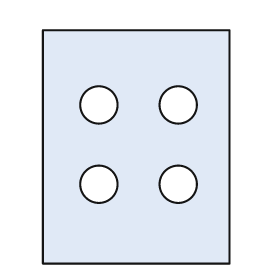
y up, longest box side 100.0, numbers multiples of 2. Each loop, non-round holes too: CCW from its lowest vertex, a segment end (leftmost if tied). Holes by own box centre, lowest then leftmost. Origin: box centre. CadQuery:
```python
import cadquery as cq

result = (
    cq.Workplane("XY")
    .moveTo(-40.0, -50.0)
    .lineTo(40.0, -50.0)
    .lineTo(40.0, 50.0)
    .lineTo(-40.0, 50.0)
    .close()
    .moveTo(-16.0, -16.0)
    .circle(8.0)
    .moveTo(18.0, -16.0)
    .circle(8.0)
    .moveTo(-16.0, 18.0)
    .circle(8.0)
    .moveTo(18.0, 18.0)
    .circle(8.0)
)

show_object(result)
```